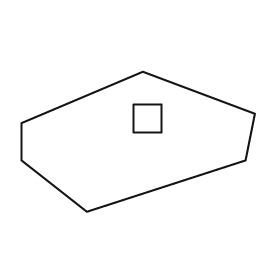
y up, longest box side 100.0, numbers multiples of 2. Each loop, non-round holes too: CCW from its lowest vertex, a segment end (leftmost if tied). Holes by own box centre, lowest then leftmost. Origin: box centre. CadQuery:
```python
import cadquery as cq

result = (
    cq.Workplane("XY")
    .moveTo(-22.0, -30.0)
    .lineTo(46.0, -8.0)
    .lineTo(50.0, 12.0)
    .lineTo(2.0, 30.0)
    .lineTo(-50.0, 8.0)
    .lineTo(-50.0, -8.0)
    .close()
    .moveTo(-2.0, 4.0)
    .lineTo(10.0, 4.0)
    .lineTo(10.0, 16.0)
    .lineTo(-2.0, 16.0)
    .close()
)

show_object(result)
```